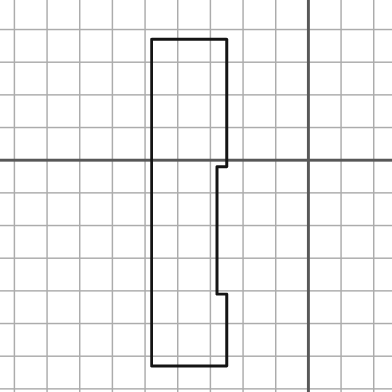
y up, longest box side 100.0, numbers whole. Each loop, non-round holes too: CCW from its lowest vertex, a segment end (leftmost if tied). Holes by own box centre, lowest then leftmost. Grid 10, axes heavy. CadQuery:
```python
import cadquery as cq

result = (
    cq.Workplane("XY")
    .moveTo(-48.0, -63.0)
    .lineTo(-25.0, -63.0)
    .lineTo(-25.0, -41.0)
    .lineTo(-28.0, -41.0)
    .lineTo(-28.0, -2.0)
    .lineTo(-25.0, -2.0)
    .lineTo(-25.0, 37.0)
    .lineTo(-48.0, 37.0)
    .close()
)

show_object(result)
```